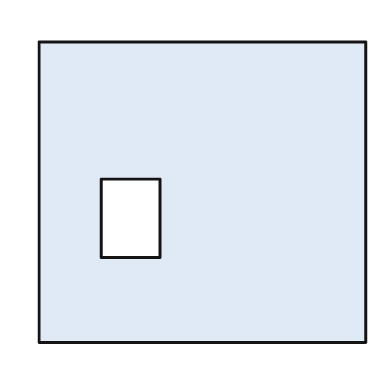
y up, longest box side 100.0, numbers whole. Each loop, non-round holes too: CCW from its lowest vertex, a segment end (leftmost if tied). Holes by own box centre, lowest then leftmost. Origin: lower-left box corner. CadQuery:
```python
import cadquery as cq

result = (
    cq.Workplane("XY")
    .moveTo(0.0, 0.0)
    .lineTo(100.0, 0.0)
    .lineTo(100.0, 92.0)
    .lineTo(0.0, 92.0)
    .close()
    .moveTo(19.0, 26.0)
    .lineTo(37.0, 26.0)
    .lineTo(37.0, 50.0)
    .lineTo(19.0, 50.0)
    .close()
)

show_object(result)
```